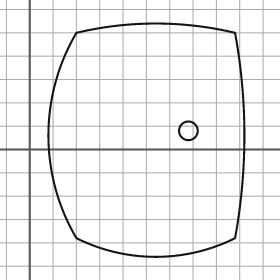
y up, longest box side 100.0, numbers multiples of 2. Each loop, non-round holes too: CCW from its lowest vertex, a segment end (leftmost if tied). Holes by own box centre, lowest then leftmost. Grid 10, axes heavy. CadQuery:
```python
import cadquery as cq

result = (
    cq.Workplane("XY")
    .moveTo(20.0, -38.0)
    .threePointArc((54.0, -46.0), (88.0, -38.0))
    .threePointArc((92.0, 6.0), (88.0, 50.0))
    .threePointArc((54.0, 54.0), (20.0, 50.0))
    .threePointArc((8.0, 6.0), (20.0, -38.0))
    .close()
    .moveTo(68.0, 8.0)
    .circle(4.0)
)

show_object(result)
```